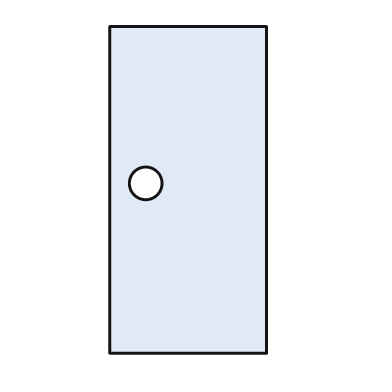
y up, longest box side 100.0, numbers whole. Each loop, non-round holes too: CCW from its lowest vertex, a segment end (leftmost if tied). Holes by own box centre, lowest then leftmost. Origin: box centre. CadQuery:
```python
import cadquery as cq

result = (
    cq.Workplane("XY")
    .moveTo(-24.0, -50.0)
    .lineTo(24.0, -50.0)
    .lineTo(24.0, 50.0)
    .lineTo(-24.0, 50.0)
    .close()
    .moveTo(-13.0, 2.0)
    .circle(5.0)
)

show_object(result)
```